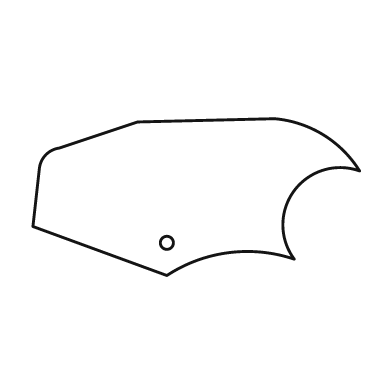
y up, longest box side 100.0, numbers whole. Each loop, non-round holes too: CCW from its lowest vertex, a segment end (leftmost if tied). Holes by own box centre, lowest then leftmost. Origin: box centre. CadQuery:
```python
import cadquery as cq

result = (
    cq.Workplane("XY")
    .moveTo(-9.0, -24.0)
    .threePointArc((10.0, -17.0), (30.0, -19.0))
    .threePointArc((30.0, 2.0), (50.0, 8.0))
    .threePointArc((39.0, 19.0), (24.0, 24.0))
    .lineTo(-18.0, 23.0)
    .lineTo(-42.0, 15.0)
    .threePointArc((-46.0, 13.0), (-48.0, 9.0))
    .lineTo(-50.0, -9.0)
    .close()
    .moveTo(-9.0, -14.0)
    .circle(2.0)
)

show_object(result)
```